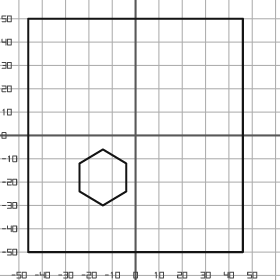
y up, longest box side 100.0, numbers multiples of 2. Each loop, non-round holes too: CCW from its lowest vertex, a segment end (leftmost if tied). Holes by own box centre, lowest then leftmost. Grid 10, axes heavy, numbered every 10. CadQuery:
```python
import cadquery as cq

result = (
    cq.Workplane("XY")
    .moveTo(-46.0, -50.0)
    .lineTo(46.0, -50.0)
    .lineTo(46.0, 50.0)
    .lineTo(-46.0, 50.0)
    .close()
    .moveTo(-14.0, -30.0)
    .lineTo(-4.0, -24.0)
    .lineTo(-4.0, -12.0)
    .lineTo(-14.0, -6.0)
    .lineTo(-24.0, -12.0)
    .lineTo(-24.0, -24.0)
    .close()
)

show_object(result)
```